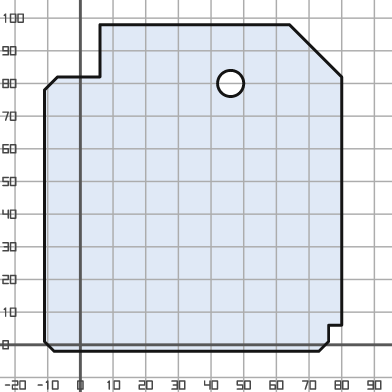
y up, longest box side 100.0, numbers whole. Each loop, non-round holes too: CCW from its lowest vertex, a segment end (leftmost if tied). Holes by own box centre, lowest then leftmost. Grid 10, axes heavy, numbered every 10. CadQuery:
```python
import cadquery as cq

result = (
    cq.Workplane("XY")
    .moveTo(-8.0, -2.0)
    .lineTo(73.0, -2.0)
    .lineTo(76.0, 1.0)
    .lineTo(76.0, 6.0)
    .lineTo(80.0, 6.0)
    .lineTo(80.0, 82.0)
    .lineTo(64.0, 98.0)
    .lineTo(6.0, 98.0)
    .lineTo(6.0, 82.0)
    .lineTo(-7.0, 82.0)
    .lineTo(-11.0, 78.0)
    .lineTo(-11.0, 1.0)
    .close()
    .moveTo(46.0, 80.0)
    .circle(4.0)
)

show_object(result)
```